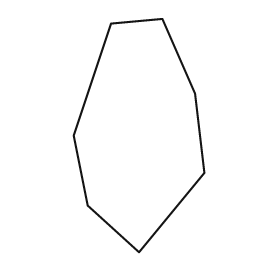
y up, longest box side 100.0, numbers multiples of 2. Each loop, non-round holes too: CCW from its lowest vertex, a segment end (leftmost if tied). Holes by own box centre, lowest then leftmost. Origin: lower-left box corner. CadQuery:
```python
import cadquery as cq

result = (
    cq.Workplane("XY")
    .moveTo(28.0, 0.0)
    .lineTo(56.0, 34.0)
    .lineTo(52.0, 68.0)
    .lineTo(38.0, 100.0)
    .lineTo(16.0, 98.0)
    .lineTo(0.0, 50.0)
    .lineTo(6.0, 20.0)
    .close()
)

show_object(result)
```